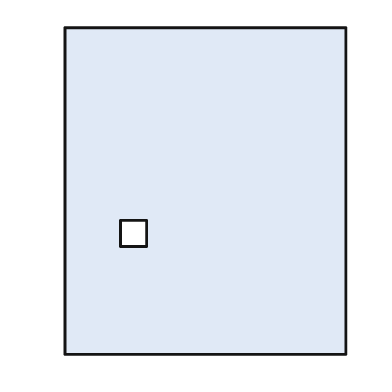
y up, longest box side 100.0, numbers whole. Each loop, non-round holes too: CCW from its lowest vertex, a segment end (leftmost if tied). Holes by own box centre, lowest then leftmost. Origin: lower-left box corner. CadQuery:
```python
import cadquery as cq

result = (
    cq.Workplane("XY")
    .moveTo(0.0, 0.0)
    .lineTo(86.0, 0.0)
    .lineTo(86.0, 100.0)
    .lineTo(0.0, 100.0)
    .close()
    .moveTo(17.0, 33.0)
    .lineTo(25.0, 33.0)
    .lineTo(25.0, 41.0)
    .lineTo(17.0, 41.0)
    .close()
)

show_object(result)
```